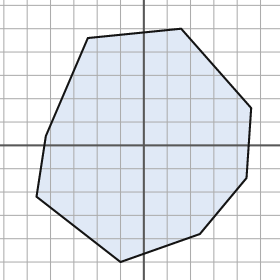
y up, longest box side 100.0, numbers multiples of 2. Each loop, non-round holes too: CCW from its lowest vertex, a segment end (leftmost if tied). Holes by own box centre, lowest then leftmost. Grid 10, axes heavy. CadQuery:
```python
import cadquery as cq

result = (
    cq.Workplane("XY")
    .moveTo(-10.0, -50.0)
    .lineTo(24.0, -38.0)
    .lineTo(44.0, -14.0)
    .lineTo(46.0, 16.0)
    .lineTo(16.0, 50.0)
    .lineTo(-24.0, 46.0)
    .lineTo(-42.0, 4.0)
    .lineTo(-46.0, -22.0)
    .close()
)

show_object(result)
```